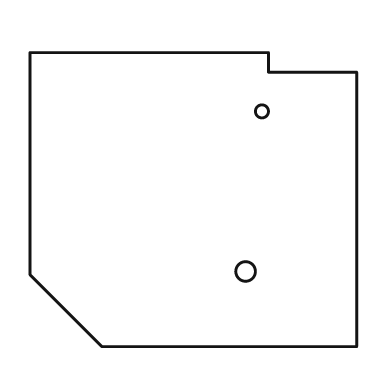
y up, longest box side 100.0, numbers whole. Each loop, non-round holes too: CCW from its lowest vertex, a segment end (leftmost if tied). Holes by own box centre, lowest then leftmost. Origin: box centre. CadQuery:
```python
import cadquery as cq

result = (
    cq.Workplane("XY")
    .moveTo(-28.0, -45.0)
    .lineTo(50.0, -45.0)
    .lineTo(50.0, 39.0)
    .lineTo(23.0, 39.0)
    .lineTo(23.0, 45.0)
    .lineTo(-50.0, 45.0)
    .lineTo(-50.0, -23.0)
    .close()
    .moveTo(16.0, -22.0)
    .circle(3.0)
    .moveTo(21.0, 27.0)
    .circle(2.0)
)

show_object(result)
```